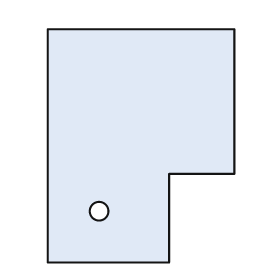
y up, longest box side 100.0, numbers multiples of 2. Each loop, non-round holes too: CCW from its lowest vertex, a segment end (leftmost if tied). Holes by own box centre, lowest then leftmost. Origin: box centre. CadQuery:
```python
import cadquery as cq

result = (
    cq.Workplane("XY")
    .moveTo(-40.0, -50.0)
    .lineTo(12.0, -50.0)
    .lineTo(12.0, -12.0)
    .lineTo(40.0, -12.0)
    .lineTo(40.0, 50.0)
    .lineTo(-40.0, 50.0)
    .close()
    .moveTo(-18.0, -28.0)
    .circle(4.0)
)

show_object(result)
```